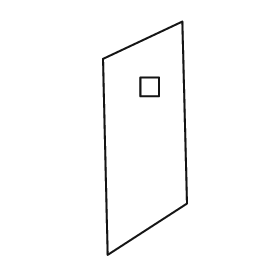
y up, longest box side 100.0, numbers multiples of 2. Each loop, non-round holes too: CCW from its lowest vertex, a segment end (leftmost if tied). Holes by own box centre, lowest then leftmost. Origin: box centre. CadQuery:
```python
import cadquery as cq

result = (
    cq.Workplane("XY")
    .moveTo(-16.0, -50.0)
    .lineTo(18.0, -28.0)
    .lineTo(16.0, 50.0)
    .lineTo(-18.0, 34.0)
    .close()
    .moveTo(-2.0, 18.0)
    .lineTo(6.0, 18.0)
    .lineTo(6.0, 26.0)
    .lineTo(-2.0, 26.0)
    .close()
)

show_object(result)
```